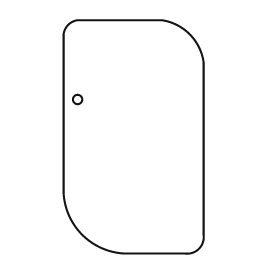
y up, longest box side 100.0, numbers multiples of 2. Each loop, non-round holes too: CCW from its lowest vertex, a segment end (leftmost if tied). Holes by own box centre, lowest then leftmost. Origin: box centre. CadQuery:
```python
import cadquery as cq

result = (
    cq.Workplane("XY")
    .moveTo(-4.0, -50.0)
    .lineTo(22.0, -50.0)
    .threePointArc((28.0, -48.0), (30.0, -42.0))
    .lineTo(30.0, 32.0)
    .threePointArc((24.0, 44.0), (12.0, 50.0))
    .lineTo(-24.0, 50.0)
    .threePointArc((-28.0, 48.0), (-30.0, 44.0))
    .lineTo(-30.0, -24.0)
    .threePointArc((-22.0, -42.0), (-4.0, -50.0))
    .close()
    .moveTo(-24.0, 16.0)
    .circle(2.0)
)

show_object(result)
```